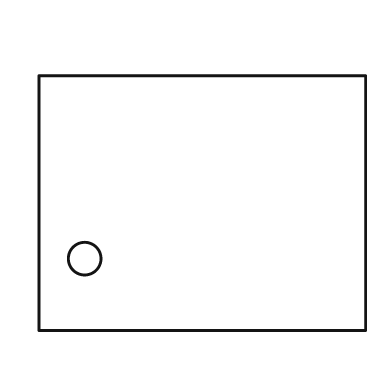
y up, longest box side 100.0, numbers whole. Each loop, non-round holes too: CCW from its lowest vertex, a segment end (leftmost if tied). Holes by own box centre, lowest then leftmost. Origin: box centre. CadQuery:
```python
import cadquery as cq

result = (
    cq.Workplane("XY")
    .moveTo(-50.0, -39.0)
    .lineTo(50.0, -39.0)
    .lineTo(50.0, 39.0)
    .lineTo(-50.0, 39.0)
    .close()
    .moveTo(-36.0, -17.0)
    .circle(5.0)
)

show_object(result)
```